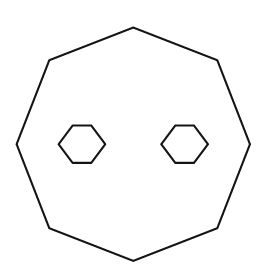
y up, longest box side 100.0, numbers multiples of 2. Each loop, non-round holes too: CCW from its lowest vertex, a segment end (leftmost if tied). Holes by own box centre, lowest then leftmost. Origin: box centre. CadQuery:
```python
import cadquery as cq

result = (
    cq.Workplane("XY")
    .moveTo(0.0, -50.0)
    .lineTo(36.0, -36.0)
    .lineTo(50.0, 0.0)
    .lineTo(36.0, 36.0)
    .lineTo(0.0, 50.0)
    .lineTo(-36.0, 36.0)
    .lineTo(-50.0, 0.0)
    .lineTo(-36.0, -36.0)
    .close()
    .moveTo(-26.0, -8.0)
    .lineTo(-18.0, -8.0)
    .lineTo(-12.0, 0.0)
    .lineTo(-18.0, 8.0)
    .lineTo(-26.0, 8.0)
    .lineTo(-32.0, 0.0)
    .close()
    .moveTo(18.0, -8.0)
    .lineTo(26.0, -8.0)
    .lineTo(32.0, 0.0)
    .lineTo(26.0, 8.0)
    .lineTo(18.0, 8.0)
    .lineTo(12.0, 0.0)
    .close()
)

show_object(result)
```